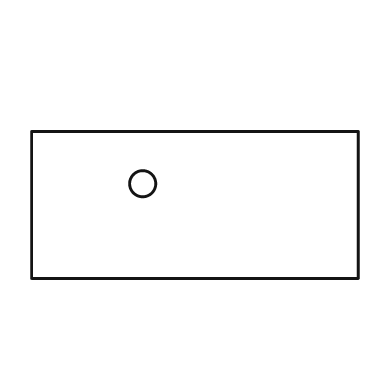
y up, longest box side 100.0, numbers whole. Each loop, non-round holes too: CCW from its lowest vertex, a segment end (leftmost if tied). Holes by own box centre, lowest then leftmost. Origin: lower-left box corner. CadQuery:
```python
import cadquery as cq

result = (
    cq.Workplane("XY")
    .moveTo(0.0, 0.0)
    .lineTo(100.0, 0.0)
    .lineTo(100.0, 45.0)
    .lineTo(0.0, 45.0)
    .close()
    .moveTo(34.0, 29.0)
    .circle(4.0)
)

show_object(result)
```